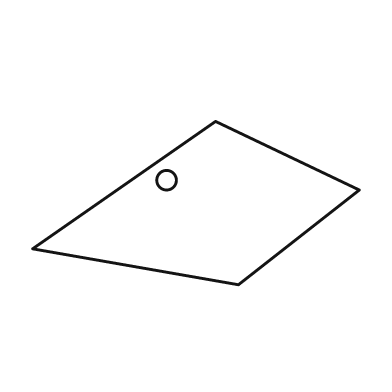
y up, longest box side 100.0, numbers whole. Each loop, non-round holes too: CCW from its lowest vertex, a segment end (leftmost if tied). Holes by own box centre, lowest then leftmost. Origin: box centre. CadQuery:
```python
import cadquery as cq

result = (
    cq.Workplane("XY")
    .moveTo(13.0, -25.0)
    .lineTo(50.0, 4.0)
    .lineTo(6.0, 25.0)
    .lineTo(-50.0, -14.0)
    .close()
    .moveTo(-9.0, 7.0)
    .circle(3.0)
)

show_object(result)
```